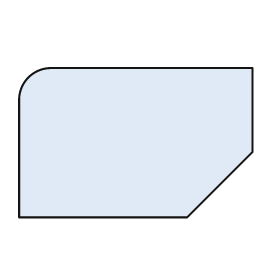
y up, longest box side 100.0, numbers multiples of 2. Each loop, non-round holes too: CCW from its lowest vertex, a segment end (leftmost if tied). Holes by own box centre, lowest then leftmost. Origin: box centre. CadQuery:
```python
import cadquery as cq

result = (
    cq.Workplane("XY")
    .moveTo(-50.0, -32.0)
    .lineTo(22.0, -32.0)
    .lineTo(50.0, -4.0)
    .lineTo(50.0, 32.0)
    .lineTo(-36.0, 32.0)
    .threePointArc((-46.0, 28.0), (-50.0, 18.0))
    .close()
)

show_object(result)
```